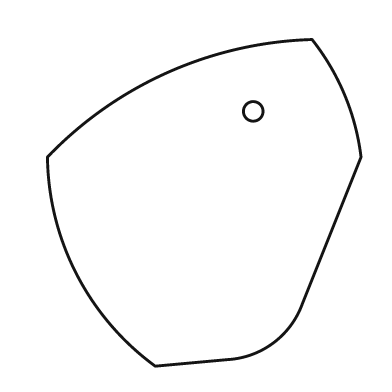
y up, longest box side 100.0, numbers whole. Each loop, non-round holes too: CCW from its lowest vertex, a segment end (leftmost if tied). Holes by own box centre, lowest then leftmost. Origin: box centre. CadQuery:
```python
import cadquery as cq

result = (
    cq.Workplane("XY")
    .moveTo(-15.0, -50.0)
    .lineTo(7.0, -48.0)
    .threePointArc((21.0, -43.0), (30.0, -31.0))
    .lineTo(48.0, 14.0)
    .threePointArc((43.0, 33.0), (33.0, 50.0))
    .threePointArc((-11.0, 40.0), (-48.0, 14.0))
    .threePointArc((-39.0, -22.0), (-15.0, -50.0))
    .close()
    .moveTo(15.0, 28.0)
    .circle(3.0)
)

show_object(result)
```